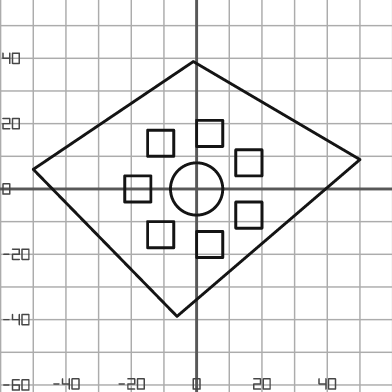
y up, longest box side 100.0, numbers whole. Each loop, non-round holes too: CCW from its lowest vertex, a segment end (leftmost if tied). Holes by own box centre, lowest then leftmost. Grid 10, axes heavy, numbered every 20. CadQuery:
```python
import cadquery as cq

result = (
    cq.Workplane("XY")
    .moveTo(-6.0, -39.0)
    .lineTo(50.0, 9.0)
    .lineTo(-1.0, 39.0)
    .lineTo(-50.0, 6.0)
    .close()
    .moveTo(0.0, -21.0)
    .lineTo(8.0, -21.0)
    .lineTo(8.0, -13.0)
    .lineTo(0.0, -13.0)
    .close()
    .moveTo(-15.0, -18.0)
    .lineTo(-7.0, -18.0)
    .lineTo(-7.0, -10.0)
    .lineTo(-15.0, -10.0)
    .close()
    .moveTo(12.0, -12.0)
    .lineTo(20.0, -12.0)
    .lineTo(20.0, -4.0)
    .lineTo(12.0, -4.0)
    .close()
    .moveTo(-22.0, -4.0)
    .lineTo(-14.0, -4.0)
    .lineTo(-14.0, 4.0)
    .lineTo(-22.0, 4.0)
    .close()
    .moveTo(0.0, 0.0)
    .circle(8.0)
    .moveTo(12.0, 4.0)
    .lineTo(20.0, 4.0)
    .lineTo(20.0, 12.0)
    .lineTo(12.0, 12.0)
    .close()
    .moveTo(-15.0, 10.0)
    .lineTo(-7.0, 10.0)
    .lineTo(-7.0, 18.0)
    .lineTo(-15.0, 18.0)
    .close()
    .moveTo(0.0, 13.0)
    .lineTo(8.0, 13.0)
    .lineTo(8.0, 21.0)
    .lineTo(0.0, 21.0)
    .close()
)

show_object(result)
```